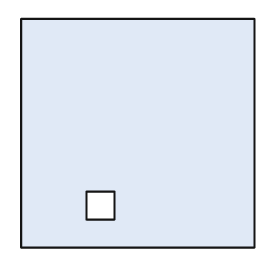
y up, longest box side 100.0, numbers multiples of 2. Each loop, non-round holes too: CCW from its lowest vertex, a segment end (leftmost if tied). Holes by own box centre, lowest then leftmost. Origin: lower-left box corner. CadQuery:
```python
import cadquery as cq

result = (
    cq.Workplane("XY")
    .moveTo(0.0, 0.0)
    .lineTo(100.0, 0.0)
    .lineTo(100.0, 98.0)
    .lineTo(0.0, 98.0)
    .close()
    .moveTo(28.0, 12.0)
    .lineTo(40.0, 12.0)
    .lineTo(40.0, 24.0)
    .lineTo(28.0, 24.0)
    .close()
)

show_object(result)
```